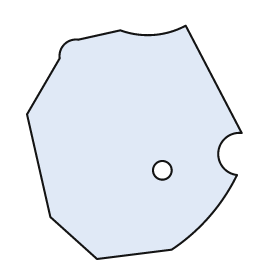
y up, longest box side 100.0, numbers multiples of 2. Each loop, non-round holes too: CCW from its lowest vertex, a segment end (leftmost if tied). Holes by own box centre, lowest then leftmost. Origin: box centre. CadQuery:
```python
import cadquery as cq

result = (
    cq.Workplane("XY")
    .moveTo(-16.0, -50.0)
    .lineTo(16.0, -46.0)
    .threePointArc((32.0, -32.0), (44.0, -14.0))
    .threePointArc((36.0, -4.0), (46.0, 4.0))
    .lineTo(22.0, 50.0)
    .threePointArc((8.0, 46.0), (-6.0, 48.0))
    .lineTo(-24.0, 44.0)
    .threePointArc((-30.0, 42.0), (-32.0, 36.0))
    .lineTo(-46.0, 12.0)
    .lineTo(-36.0, -32.0)
    .close()
    .moveTo(12.0, -12.0)
    .circle(4.0)
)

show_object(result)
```